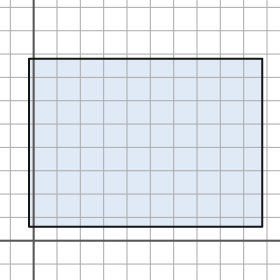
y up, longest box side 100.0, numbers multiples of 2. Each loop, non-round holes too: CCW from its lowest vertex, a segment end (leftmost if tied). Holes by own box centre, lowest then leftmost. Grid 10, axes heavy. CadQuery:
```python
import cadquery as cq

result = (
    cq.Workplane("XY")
    .moveTo(-2.0, 6.0)
    .lineTo(98.0, 6.0)
    .lineTo(98.0, 78.0)
    .lineTo(-2.0, 78.0)
    .close()
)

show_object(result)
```